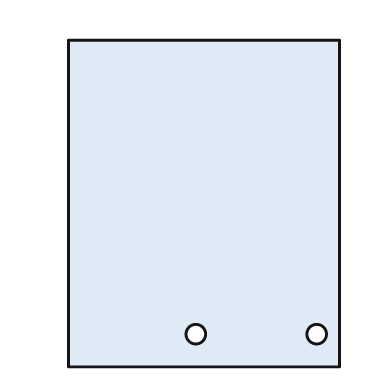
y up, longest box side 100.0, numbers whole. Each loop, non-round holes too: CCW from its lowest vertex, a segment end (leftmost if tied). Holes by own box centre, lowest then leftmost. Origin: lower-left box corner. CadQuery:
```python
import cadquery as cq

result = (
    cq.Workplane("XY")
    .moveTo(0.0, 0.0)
    .lineTo(83.0, 0.0)
    .lineTo(83.0, 100.0)
    .lineTo(0.0, 100.0)
    .close()
    .moveTo(39.0, 10.0)
    .circle(3.0)
    .moveTo(76.0, 10.0)
    .circle(3.0)
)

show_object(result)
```